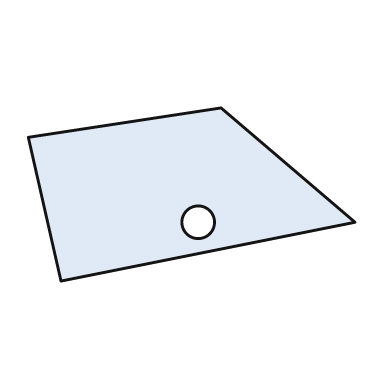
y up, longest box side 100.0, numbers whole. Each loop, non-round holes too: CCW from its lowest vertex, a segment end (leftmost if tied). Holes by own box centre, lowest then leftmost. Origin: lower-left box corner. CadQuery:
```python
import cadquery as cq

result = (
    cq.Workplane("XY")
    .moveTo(10.0, 0.0)
    .lineTo(100.0, 18.0)
    .lineTo(59.0, 53.0)
    .lineTo(0.0, 44.0)
    .close()
    .moveTo(52.0, 18.0)
    .circle(5.0)
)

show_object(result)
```